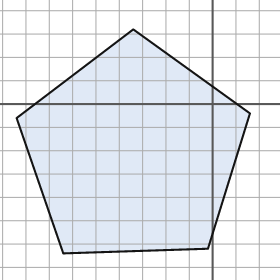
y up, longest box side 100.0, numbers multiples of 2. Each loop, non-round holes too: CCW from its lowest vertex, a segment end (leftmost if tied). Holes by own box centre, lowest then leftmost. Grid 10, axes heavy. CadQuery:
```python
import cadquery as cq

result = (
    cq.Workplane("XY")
    .moveTo(-64.0, -64.0)
    .lineTo(-2.0, -62.0)
    .lineTo(16.0, -4.0)
    .lineTo(-34.0, 32.0)
    .lineTo(-84.0, -6.0)
    .close()
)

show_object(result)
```